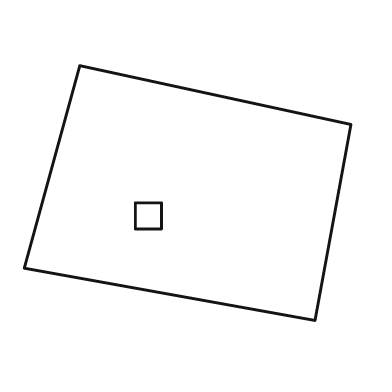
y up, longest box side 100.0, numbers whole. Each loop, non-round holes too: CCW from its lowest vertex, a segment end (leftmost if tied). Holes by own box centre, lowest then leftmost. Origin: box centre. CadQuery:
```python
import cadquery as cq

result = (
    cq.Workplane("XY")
    .moveTo(39.0, -39.0)
    .lineTo(50.0, 21.0)
    .lineTo(-33.0, 39.0)
    .lineTo(-50.0, -23.0)
    .close()
    .moveTo(-16.0, -11.0)
    .lineTo(-8.0, -11.0)
    .lineTo(-8.0, -3.0)
    .lineTo(-16.0, -3.0)
    .close()
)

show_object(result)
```